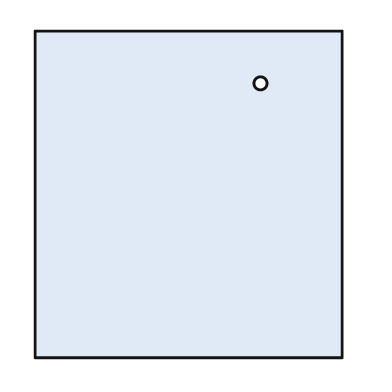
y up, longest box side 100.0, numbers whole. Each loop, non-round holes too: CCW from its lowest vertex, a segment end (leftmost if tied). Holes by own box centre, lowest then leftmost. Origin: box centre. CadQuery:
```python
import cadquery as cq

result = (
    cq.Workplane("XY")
    .moveTo(-47.0, -50.0)
    .lineTo(47.0, -50.0)
    .lineTo(47.0, 50.0)
    .lineTo(-47.0, 50.0)
    .close()
    .moveTo(22.0, 34.0)
    .circle(2.0)
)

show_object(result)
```